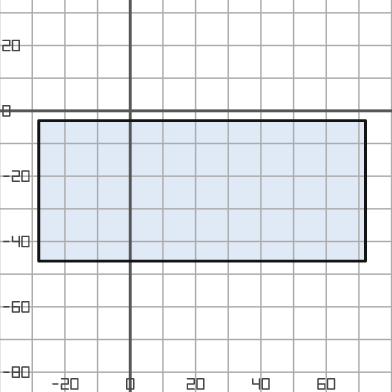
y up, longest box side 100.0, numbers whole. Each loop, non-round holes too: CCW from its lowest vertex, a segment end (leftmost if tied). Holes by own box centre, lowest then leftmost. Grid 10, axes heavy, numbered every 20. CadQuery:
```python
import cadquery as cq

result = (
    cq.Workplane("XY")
    .moveTo(-28.0, -46.0)
    .lineTo(72.0, -46.0)
    .lineTo(72.0, -3.0)
    .lineTo(-28.0, -3.0)
    .close()
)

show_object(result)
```